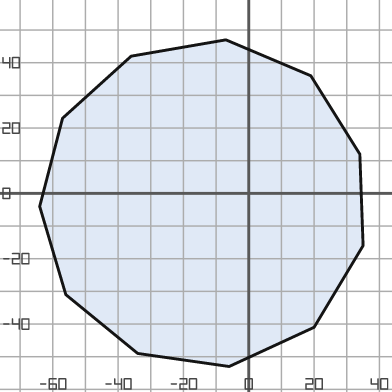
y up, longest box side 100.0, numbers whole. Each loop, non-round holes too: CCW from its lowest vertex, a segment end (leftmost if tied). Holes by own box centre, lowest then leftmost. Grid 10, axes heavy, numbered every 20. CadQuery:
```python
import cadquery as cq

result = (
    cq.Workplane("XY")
    .moveTo(-6.0, -53.0)
    .lineTo(20.0, -41.0)
    .lineTo(35.0, -16.0)
    .lineTo(34.0, 12.0)
    .lineTo(19.0, 36.0)
    .lineTo(-7.0, 47.0)
    .lineTo(-36.0, 42.0)
    .lineTo(-57.0, 23.0)
    .lineTo(-64.0, -4.0)
    .lineTo(-56.0, -31.0)
    .lineTo(-34.0, -49.0)
    .close()
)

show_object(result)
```